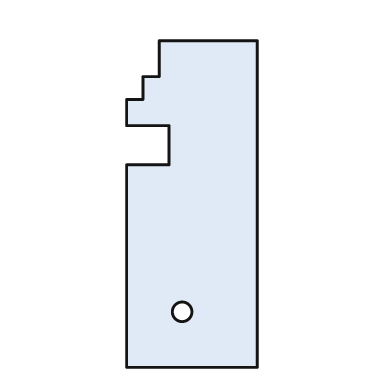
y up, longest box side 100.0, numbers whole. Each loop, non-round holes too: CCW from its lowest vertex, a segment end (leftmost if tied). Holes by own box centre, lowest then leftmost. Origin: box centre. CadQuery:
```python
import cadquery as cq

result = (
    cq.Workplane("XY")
    .moveTo(-20.0, -50.0)
    .lineTo(20.0, -50.0)
    .lineTo(20.0, 50.0)
    .lineTo(-10.0, 50.0)
    .lineTo(-10.0, 39.0)
    .lineTo(-15.0, 39.0)
    .lineTo(-15.0, 32.0)
    .lineTo(-20.0, 32.0)
    .lineTo(-20.0, 24.0)
    .lineTo(-7.0, 24.0)
    .lineTo(-7.0, 12.0)
    .lineTo(-20.0, 12.0)
    .close()
    .moveTo(-3.0, -33.0)
    .circle(3.0)
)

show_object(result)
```